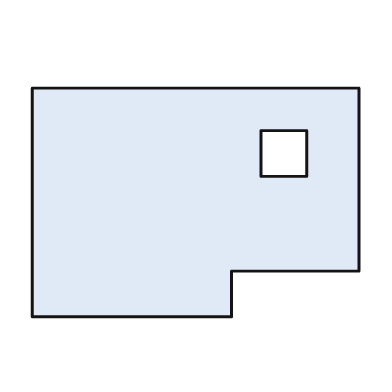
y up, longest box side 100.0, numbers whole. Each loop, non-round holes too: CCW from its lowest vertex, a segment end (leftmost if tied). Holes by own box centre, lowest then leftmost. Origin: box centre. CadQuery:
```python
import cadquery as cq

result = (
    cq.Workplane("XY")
    .moveTo(-50.0, -35.0)
    .lineTo(11.0, -35.0)
    .lineTo(11.0, -21.0)
    .lineTo(50.0, -21.0)
    .lineTo(50.0, 35.0)
    .lineTo(-50.0, 35.0)
    .close()
    .moveTo(20.0, 8.0)
    .lineTo(34.0, 8.0)
    .lineTo(34.0, 22.0)
    .lineTo(20.0, 22.0)
    .close()
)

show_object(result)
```